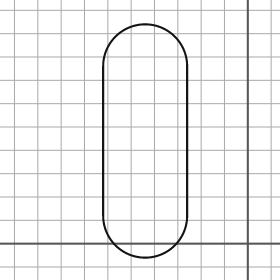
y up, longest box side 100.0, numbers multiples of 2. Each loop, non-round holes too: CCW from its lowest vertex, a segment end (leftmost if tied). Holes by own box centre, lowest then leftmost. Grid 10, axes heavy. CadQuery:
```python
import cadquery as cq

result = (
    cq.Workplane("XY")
    .moveTo(-62.0, 12.0)
    .threePointArc((-44.0, -6.0), (-26.0, 12.0))
    .lineTo(-26.0, 76.0)
    .threePointArc((-44.0, 94.0), (-62.0, 76.0))
    .close()
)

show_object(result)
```